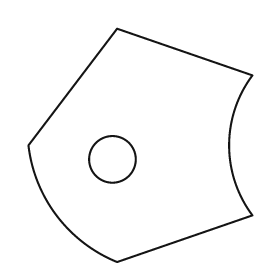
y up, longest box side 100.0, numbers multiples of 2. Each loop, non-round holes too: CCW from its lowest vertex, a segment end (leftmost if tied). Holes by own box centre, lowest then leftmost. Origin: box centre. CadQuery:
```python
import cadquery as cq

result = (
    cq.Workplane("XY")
    .moveTo(-10.0, -50.0)
    .lineTo(48.0, -30.0)
    .threePointArc((38.0, 0.0), (48.0, 30.0))
    .lineTo(-10.0, 50.0)
    .lineTo(-48.0, 0.0)
    .threePointArc((-36.0, -30.0), (-10.0, -50.0))
    .close()
    .moveTo(-12.0, -6.0)
    .circle(10.0)
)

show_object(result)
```